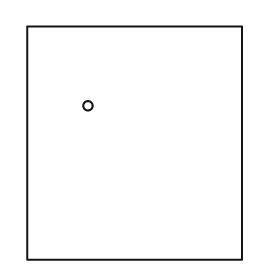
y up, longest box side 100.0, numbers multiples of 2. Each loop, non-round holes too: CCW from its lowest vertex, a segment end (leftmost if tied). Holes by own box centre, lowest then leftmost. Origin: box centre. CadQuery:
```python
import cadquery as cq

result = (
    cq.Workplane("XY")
    .moveTo(-46.0, -50.0)
    .lineTo(46.0, -50.0)
    .lineTo(46.0, 50.0)
    .lineTo(-46.0, 50.0)
    .close()
    .moveTo(-20.0, 16.0)
    .circle(2.0)
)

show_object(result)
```